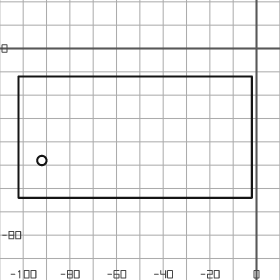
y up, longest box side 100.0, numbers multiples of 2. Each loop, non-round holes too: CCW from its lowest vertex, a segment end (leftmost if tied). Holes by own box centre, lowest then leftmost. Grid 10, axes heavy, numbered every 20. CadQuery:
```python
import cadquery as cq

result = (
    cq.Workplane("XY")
    .moveTo(-102.0, -64.0)
    .lineTo(-2.0, -64.0)
    .lineTo(-2.0, -12.0)
    .lineTo(-102.0, -12.0)
    .close()
    .moveTo(-92.0, -48.0)
    .circle(2.0)
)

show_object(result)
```